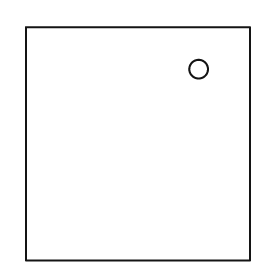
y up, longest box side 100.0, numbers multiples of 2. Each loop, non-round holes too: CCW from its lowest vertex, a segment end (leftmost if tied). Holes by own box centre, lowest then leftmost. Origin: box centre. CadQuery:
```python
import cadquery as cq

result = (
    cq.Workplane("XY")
    .moveTo(-48.0, -50.0)
    .lineTo(48.0, -50.0)
    .lineTo(48.0, 50.0)
    .lineTo(-48.0, 50.0)
    .close()
    .moveTo(26.0, 32.0)
    .circle(4.0)
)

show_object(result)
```